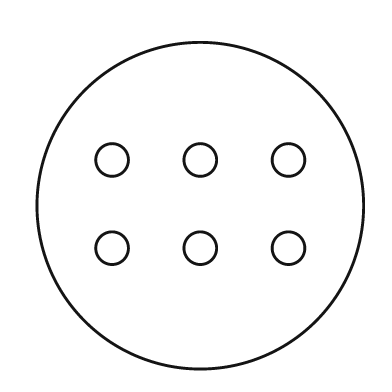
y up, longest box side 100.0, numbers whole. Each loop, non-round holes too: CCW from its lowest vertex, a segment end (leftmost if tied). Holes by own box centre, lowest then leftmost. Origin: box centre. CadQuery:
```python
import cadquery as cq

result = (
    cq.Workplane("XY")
    .moveTo(0.0, 0.0)
    .circle(50.0)
    .moveTo(-27.0, -13.0)
    .circle(5.0)
    .moveTo(0.0, -13.0)
    .circle(5.0)
    .moveTo(27.0, -13.0)
    .circle(5.0)
    .moveTo(-27.0, 14.0)
    .circle(5.0)
    .moveTo(0.0, 14.0)
    .circle(5.0)
    .moveTo(27.0, 14.0)
    .circle(5.0)
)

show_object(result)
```